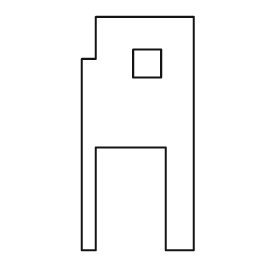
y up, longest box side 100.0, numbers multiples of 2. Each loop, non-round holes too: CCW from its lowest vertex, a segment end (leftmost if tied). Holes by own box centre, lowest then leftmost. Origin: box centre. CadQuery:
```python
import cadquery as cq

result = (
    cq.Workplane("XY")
    .moveTo(-24.0, -50.0)
    .lineTo(-18.0, -50.0)
    .lineTo(-18.0, -6.0)
    .lineTo(12.0, -6.0)
    .lineTo(12.0, -50.0)
    .lineTo(24.0, -50.0)
    .lineTo(24.0, 50.0)
    .lineTo(-18.0, 50.0)
    .lineTo(-18.0, 32.0)
    .lineTo(-24.0, 32.0)
    .close()
    .moveTo(-2.0, 24.0)
    .lineTo(10.0, 24.0)
    .lineTo(10.0, 36.0)
    .lineTo(-2.0, 36.0)
    .close()
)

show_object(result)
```